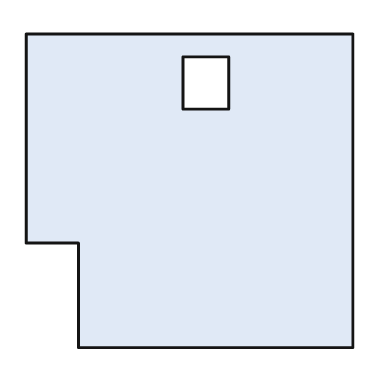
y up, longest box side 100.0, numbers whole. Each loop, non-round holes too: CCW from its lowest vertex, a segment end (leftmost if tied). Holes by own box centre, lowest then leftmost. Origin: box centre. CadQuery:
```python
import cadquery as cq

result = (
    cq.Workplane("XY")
    .moveTo(-34.0, -48.0)
    .lineTo(50.0, -48.0)
    .lineTo(50.0, 48.0)
    .lineTo(-50.0, 48.0)
    .lineTo(-50.0, -16.0)
    .lineTo(-34.0, -16.0)
    .close()
    .moveTo(-2.0, 25.0)
    .lineTo(12.0, 25.0)
    .lineTo(12.0, 41.0)
    .lineTo(-2.0, 41.0)
    .close()
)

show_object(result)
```